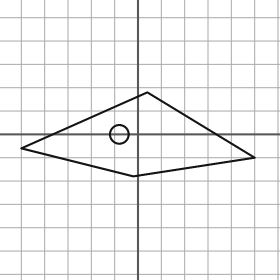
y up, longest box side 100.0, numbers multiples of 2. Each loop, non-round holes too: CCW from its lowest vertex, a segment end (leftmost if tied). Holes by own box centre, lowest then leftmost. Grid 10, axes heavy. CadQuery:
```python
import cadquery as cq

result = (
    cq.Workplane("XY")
    .moveTo(-2.0, -18.0)
    .lineTo(50.0, -10.0)
    .lineTo(4.0, 18.0)
    .lineTo(-50.0, -6.0)
    .close()
    .moveTo(-8.0, 0.0)
    .circle(4.0)
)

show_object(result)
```